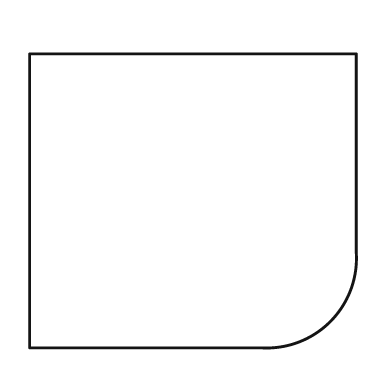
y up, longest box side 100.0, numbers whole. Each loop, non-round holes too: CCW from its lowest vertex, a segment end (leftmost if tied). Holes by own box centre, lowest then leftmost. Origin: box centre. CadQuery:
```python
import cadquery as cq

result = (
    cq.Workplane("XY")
    .moveTo(-50.0, -45.0)
    .lineTo(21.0, -45.0)
    .threePointArc((42.0, -37.0), (50.0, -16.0))
    .lineTo(50.0, 45.0)
    .lineTo(-50.0, 45.0)
    .close()
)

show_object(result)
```